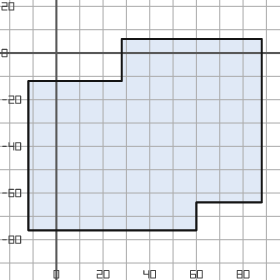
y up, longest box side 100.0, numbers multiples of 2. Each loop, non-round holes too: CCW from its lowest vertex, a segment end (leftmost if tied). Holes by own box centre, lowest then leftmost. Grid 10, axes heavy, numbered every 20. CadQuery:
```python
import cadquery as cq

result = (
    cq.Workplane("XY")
    .moveTo(-12.0, -76.0)
    .lineTo(60.0, -76.0)
    .lineTo(60.0, -64.0)
    .lineTo(88.0, -64.0)
    .lineTo(88.0, 6.0)
    .lineTo(28.0, 6.0)
    .lineTo(28.0, -12.0)
    .lineTo(-12.0, -12.0)
    .close()
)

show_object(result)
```